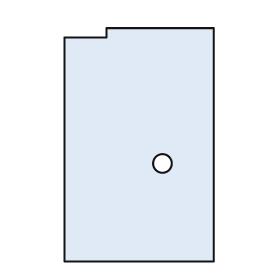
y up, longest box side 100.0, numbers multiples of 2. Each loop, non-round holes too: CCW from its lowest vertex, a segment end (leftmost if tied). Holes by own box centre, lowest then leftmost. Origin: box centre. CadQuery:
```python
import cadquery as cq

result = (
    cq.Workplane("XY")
    .moveTo(-32.0, -50.0)
    .lineTo(32.0, -50.0)
    .lineTo(32.0, 50.0)
    .lineTo(-14.0, 50.0)
    .lineTo(-14.0, 46.0)
    .lineTo(-32.0, 46.0)
    .close()
    .moveTo(10.0, -8.0)
    .circle(4.0)
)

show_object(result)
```